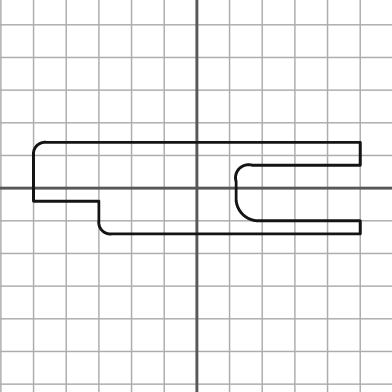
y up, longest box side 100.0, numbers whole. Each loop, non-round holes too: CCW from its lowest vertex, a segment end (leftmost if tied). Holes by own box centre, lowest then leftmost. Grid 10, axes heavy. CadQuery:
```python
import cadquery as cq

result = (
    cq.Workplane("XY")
    .moveTo(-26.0, -14.0)
    .lineTo(50.0, -14.0)
    .lineTo(50.0, -10.0)
    .lineTo(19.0, -10.0)
    .threePointArc((14.0, -8.0), (12.0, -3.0))
    .lineTo(12.0, 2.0)
    .threePointArc((13.0, 6.0), (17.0, 7.0))
    .lineTo(50.0, 7.0)
    .lineTo(50.0, 14.0)
    .lineTo(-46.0, 14.0)
    .threePointArc((-49.0, 13.0), (-50.0, 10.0))
    .lineTo(-50.0, -4.0)
    .lineTo(-30.0, -4.0)
    .lineTo(-30.0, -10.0)
    .threePointArc((-29.0, -13.0), (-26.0, -14.0))
    .close()
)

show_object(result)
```